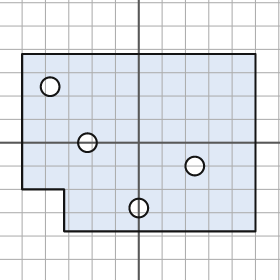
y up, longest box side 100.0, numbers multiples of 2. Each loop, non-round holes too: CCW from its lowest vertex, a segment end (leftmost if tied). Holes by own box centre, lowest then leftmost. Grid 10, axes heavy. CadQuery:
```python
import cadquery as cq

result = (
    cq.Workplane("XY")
    .moveTo(-32.0, -38.0)
    .lineTo(50.0, -38.0)
    .lineTo(50.0, 38.0)
    .lineTo(-50.0, 38.0)
    .lineTo(-50.0, -20.0)
    .lineTo(-32.0, -20.0)
    .close()
    .moveTo(0.0, -28.0)
    .circle(4.0)
    .moveTo(24.0, -10.0)
    .circle(4.0)
    .moveTo(-22.0, 0.0)
    .circle(4.0)
    .moveTo(-38.0, 24.0)
    .circle(4.0)
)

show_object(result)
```